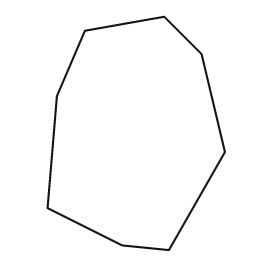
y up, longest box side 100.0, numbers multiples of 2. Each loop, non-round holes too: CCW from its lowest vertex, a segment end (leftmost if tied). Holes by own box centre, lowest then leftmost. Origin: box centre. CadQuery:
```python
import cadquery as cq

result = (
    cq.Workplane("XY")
    .moveTo(14.0, -50.0)
    .lineTo(38.0, -8.0)
    .lineTo(28.0, 34.0)
    .lineTo(12.0, 50.0)
    .lineTo(-22.0, 44.0)
    .lineTo(-34.0, 16.0)
    .lineTo(-38.0, -32.0)
    .lineTo(-6.0, -48.0)
    .close()
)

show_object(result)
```